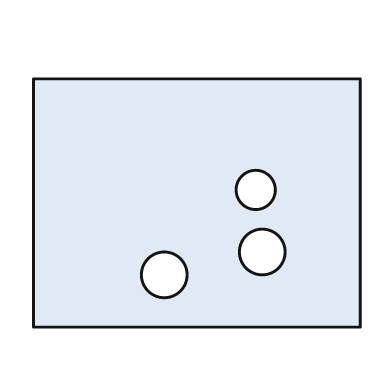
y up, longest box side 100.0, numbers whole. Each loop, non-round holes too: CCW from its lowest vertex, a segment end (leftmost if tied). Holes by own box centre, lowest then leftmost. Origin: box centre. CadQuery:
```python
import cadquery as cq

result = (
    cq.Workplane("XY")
    .moveTo(-50.0, -38.0)
    .lineTo(50.0, -38.0)
    .lineTo(50.0, 38.0)
    .lineTo(-50.0, 38.0)
    .close()
    .moveTo(-10.0, -22.0)
    .circle(7.0)
    .moveTo(20.0, -15.0)
    .circle(7.0)
    .moveTo(18.0, 4.0)
    .circle(6.0)
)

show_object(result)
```